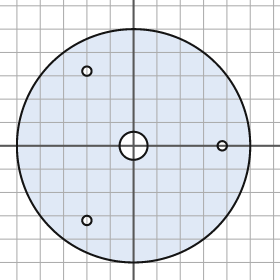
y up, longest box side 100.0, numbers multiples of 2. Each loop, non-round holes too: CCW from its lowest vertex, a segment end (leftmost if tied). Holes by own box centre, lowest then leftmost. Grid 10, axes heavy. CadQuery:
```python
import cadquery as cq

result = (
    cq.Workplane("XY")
    .moveTo(0.0, 0.0)
    .circle(50.0)
    .moveTo(-20.0, -32.0)
    .circle(2.0)
    .moveTo(0.0, 0.0)
    .circle(6.0)
    .moveTo(38.0, 0.0)
    .circle(2.0)
    .moveTo(-20.0, 32.0)
    .circle(2.0)
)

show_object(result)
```